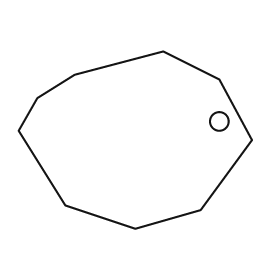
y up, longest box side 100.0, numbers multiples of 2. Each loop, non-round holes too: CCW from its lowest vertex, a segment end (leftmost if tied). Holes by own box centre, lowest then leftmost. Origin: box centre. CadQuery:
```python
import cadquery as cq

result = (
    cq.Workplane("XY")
    .moveTo(0.0, -38.0)
    .lineTo(28.0, -30.0)
    .lineTo(50.0, 0.0)
    .lineTo(36.0, 26.0)
    .lineTo(12.0, 38.0)
    .lineTo(-26.0, 28.0)
    .lineTo(-42.0, 18.0)
    .lineTo(-50.0, 4.0)
    .lineTo(-30.0, -28.0)
    .close()
    .moveTo(36.0, 8.0)
    .circle(4.0)
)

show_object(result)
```